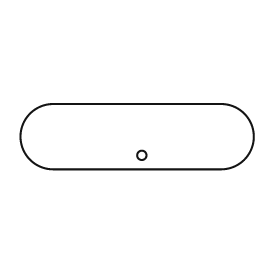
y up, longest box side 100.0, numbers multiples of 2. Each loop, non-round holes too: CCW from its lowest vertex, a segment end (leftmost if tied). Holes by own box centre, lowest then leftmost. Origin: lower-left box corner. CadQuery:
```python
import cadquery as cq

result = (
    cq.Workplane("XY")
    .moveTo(14.0, 0.0)
    .lineTo(86.0, 0.0)
    .threePointArc((100.0, 14.0), (86.0, 28.0))
    .lineTo(14.0, 28.0)
    .threePointArc((0.0, 14.0), (14.0, 0.0))
    .close()
    .moveTo(52.0, 6.0)
    .circle(2.0)
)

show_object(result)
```